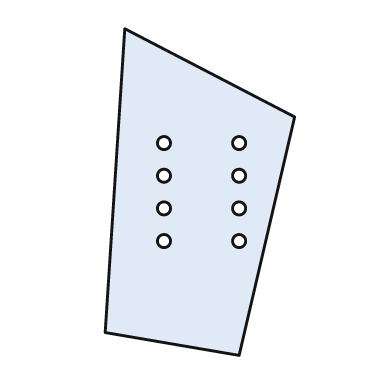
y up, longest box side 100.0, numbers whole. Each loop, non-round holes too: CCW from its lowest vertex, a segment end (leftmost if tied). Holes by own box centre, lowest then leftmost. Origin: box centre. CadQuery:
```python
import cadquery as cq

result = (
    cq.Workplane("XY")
    .moveTo(12.0, -50.0)
    .lineTo(29.0, 23.0)
    .lineTo(-23.0, 50.0)
    .lineTo(-29.0, -43.0)
    .close()
    .moveTo(-11.0, -15.0)
    .circle(2.0)
    .moveTo(12.0, -15.0)
    .circle(2.0)
    .moveTo(-11.0, -5.0)
    .circle(2.0)
    .moveTo(12.0, -5.0)
    .circle(2.0)
    .moveTo(-11.0, 5.0)
    .circle(2.0)
    .moveTo(12.0, 5.0)
    .circle(2.0)
    .moveTo(-11.0, 15.0)
    .circle(2.0)
    .moveTo(12.0, 15.0)
    .circle(2.0)
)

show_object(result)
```